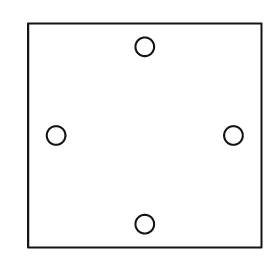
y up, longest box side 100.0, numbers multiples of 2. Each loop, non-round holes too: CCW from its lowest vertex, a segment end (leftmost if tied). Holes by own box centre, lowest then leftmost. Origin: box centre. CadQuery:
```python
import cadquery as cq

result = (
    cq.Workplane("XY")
    .moveTo(-50.0, -48.0)
    .lineTo(50.0, -48.0)
    .lineTo(50.0, 48.0)
    .lineTo(-50.0, 48.0)
    .close()
    .moveTo(0.0, -38.0)
    .circle(4.0)
    .moveTo(-38.0, 0.0)
    .circle(4.0)
    .moveTo(38.0, 0.0)
    .circle(4.0)
    .moveTo(0.0, 38.0)
    .circle(4.0)
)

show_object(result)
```